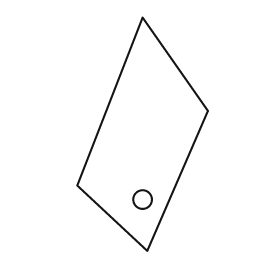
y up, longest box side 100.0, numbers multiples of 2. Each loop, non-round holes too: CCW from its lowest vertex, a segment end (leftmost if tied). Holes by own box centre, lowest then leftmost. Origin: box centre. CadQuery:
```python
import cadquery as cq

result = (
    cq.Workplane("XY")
    .moveTo(2.0, -50.0)
    .lineTo(28.0, 10.0)
    .lineTo(0.0, 50.0)
    .lineTo(-28.0, -22.0)
    .close()
    .moveTo(0.0, -28.0)
    .circle(4.0)
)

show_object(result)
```